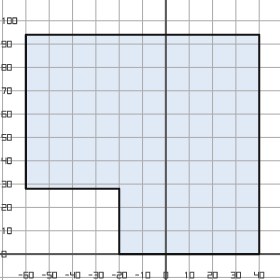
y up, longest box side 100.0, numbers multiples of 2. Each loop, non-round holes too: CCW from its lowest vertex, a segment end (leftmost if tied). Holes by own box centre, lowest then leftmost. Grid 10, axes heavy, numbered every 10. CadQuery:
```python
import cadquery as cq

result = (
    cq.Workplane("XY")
    .moveTo(-20.0, 0.0)
    .lineTo(40.0, 0.0)
    .lineTo(40.0, 94.0)
    .lineTo(-60.0, 94.0)
    .lineTo(-60.0, 28.0)
    .lineTo(-20.0, 28.0)
    .close()
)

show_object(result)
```